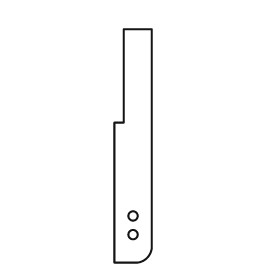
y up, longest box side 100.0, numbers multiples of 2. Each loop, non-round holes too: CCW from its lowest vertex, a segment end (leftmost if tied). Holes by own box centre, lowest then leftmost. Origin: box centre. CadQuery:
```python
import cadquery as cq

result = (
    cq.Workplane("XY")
    .moveTo(-8.0, -50.0)
    .lineTo(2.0, -50.0)
    .threePointArc((6.0, -48.0), (8.0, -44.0))
    .lineTo(8.0, 50.0)
    .lineTo(-4.0, 50.0)
    .lineTo(-4.0, 10.0)
    .lineTo(-8.0, 10.0)
    .close()
    .moveTo(0.0, -38.0)
    .circle(2.0)
    .moveTo(0.0, -30.0)
    .circle(2.0)
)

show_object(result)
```